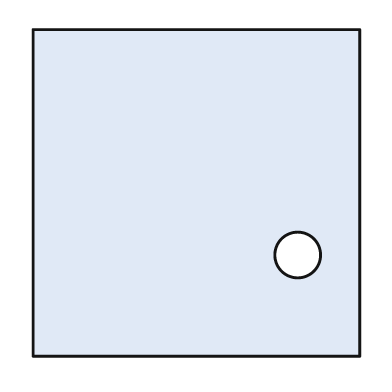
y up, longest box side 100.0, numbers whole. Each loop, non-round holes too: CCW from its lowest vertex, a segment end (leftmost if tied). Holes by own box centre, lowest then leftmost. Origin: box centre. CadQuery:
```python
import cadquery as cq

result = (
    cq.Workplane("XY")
    .moveTo(-50.0, -50.0)
    .lineTo(50.0, -50.0)
    .lineTo(50.0, 50.0)
    .lineTo(-50.0, 50.0)
    .close()
    .moveTo(31.0, -19.0)
    .circle(7.0)
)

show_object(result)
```